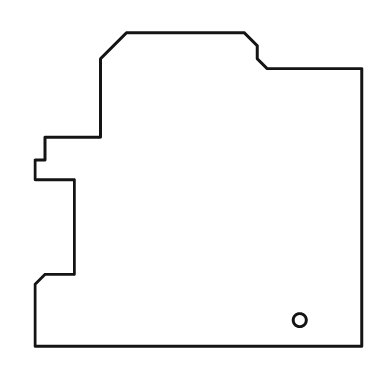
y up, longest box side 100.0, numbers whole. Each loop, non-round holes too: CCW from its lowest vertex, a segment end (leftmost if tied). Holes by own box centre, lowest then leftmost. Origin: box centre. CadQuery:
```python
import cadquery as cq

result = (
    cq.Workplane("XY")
    .moveTo(-50.0, -48.0)
    .lineTo(50.0, -48.0)
    .lineTo(50.0, 37.0)
    .lineTo(21.0, 37.0)
    .lineTo(18.0, 40.0)
    .lineTo(18.0, 44.0)
    .lineTo(14.0, 48.0)
    .lineTo(-22.0, 48.0)
    .lineTo(-30.0, 40.0)
    .lineTo(-30.0, 16.0)
    .lineTo(-47.0, 16.0)
    .lineTo(-47.0, 9.0)
    .lineTo(-50.0, 9.0)
    .lineTo(-50.0, 3.0)
    .lineTo(-38.0, 3.0)
    .lineTo(-38.0, -26.0)
    .lineTo(-47.0, -26.0)
    .lineTo(-50.0, -29.0)
    .close()
    .moveTo(31.0, -40.0)
    .circle(2.0)
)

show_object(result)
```